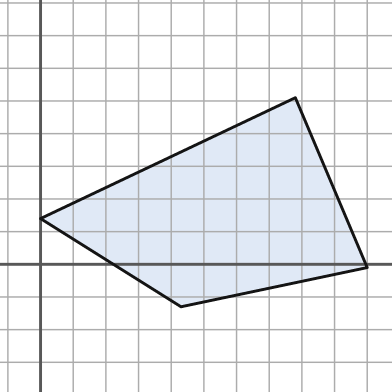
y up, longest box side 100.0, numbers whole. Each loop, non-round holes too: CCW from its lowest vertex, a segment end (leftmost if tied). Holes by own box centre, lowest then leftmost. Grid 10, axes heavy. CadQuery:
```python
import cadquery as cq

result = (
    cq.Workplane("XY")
    .moveTo(43.0, -13.0)
    .lineTo(100.0, -1.0)
    .lineTo(78.0, 51.0)
    .lineTo(0.0, 14.0)
    .close()
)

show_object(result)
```